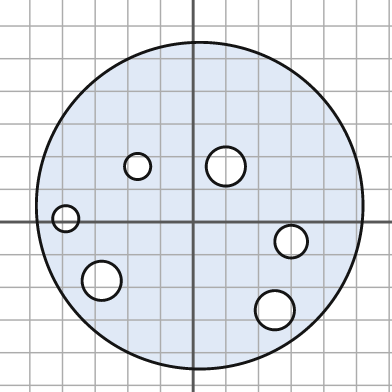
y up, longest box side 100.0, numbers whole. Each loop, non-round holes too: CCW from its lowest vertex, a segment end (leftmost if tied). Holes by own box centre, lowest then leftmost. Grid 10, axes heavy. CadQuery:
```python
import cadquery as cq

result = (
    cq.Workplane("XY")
    .moveTo(2.0, 5.0)
    .circle(50.0)
    .moveTo(25.0, -27.0)
    .circle(6.0)
    .moveTo(-28.0, -18.0)
    .circle(6.0)
    .moveTo(30.0, -6.0)
    .circle(5.0)
    .moveTo(-39.0, 1.0)
    .circle(4.0)
    .moveTo(-17.0, 17.0)
    .circle(4.0)
    .moveTo(10.0, 17.0)
    .circle(6.0)
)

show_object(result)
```